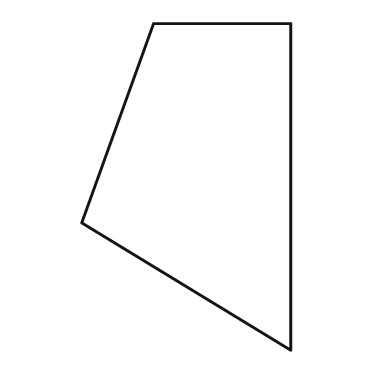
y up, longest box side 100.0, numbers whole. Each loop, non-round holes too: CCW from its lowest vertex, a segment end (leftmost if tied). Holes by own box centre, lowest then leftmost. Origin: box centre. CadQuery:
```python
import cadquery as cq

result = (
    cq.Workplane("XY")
    .moveTo(32.0, -50.0)
    .lineTo(32.0, 50.0)
    .lineTo(-10.0, 50.0)
    .lineTo(-32.0, -11.0)
    .close()
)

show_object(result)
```